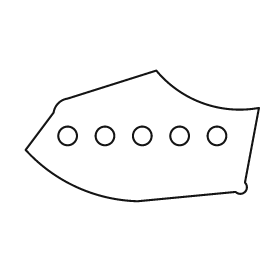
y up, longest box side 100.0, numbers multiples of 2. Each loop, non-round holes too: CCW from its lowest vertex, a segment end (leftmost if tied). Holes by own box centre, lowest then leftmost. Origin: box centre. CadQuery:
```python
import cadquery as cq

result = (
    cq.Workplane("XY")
    .moveTo(-2.0, -28.0)
    .lineTo(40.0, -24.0)
    .threePointArc((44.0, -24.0), (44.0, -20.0))
    .lineTo(50.0, 12.0)
    .threePointArc((26.0, 14.0), (6.0, 28.0))
    .lineTo(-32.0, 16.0)
    .threePointArc((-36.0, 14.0), (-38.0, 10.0))
    .lineTo(-50.0, -6.0)
    .threePointArc((-28.0, -22.0), (-2.0, -28.0))
    .close()
    .moveTo(-32.0, 0.0)
    .circle(4.0)
    .moveTo(-16.0, 0.0)
    .circle(4.0)
    .moveTo(0.0, 0.0)
    .circle(4.0)
    .moveTo(16.0, 0.0)
    .circle(4.0)
    .moveTo(32.0, 0.0)
    .circle(4.0)
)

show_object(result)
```